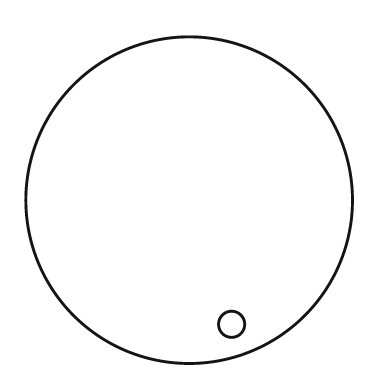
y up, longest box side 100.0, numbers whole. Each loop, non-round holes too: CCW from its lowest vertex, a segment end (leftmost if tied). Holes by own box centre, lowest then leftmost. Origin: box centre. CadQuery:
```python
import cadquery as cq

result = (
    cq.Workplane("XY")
    .moveTo(0.0, 0.0)
    .circle(50.0)
    .moveTo(13.0, -38.0)
    .circle(4.0)
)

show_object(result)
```